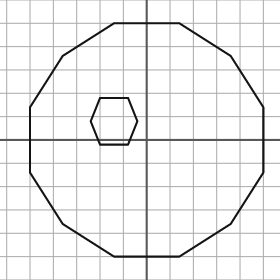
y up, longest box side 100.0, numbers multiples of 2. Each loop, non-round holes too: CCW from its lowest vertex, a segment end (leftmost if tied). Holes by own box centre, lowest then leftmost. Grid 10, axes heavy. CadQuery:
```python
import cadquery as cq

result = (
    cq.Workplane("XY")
    .moveTo(-14.0, -50.0)
    .lineTo(14.0, -50.0)
    .lineTo(36.0, -36.0)
    .lineTo(50.0, -14.0)
    .lineTo(50.0, 14.0)
    .lineTo(36.0, 36.0)
    .lineTo(14.0, 50.0)
    .lineTo(-14.0, 50.0)
    .lineTo(-36.0, 36.0)
    .lineTo(-50.0, 14.0)
    .lineTo(-50.0, -14.0)
    .lineTo(-36.0, -36.0)
    .close()
    .moveTo(-20.0, -2.0)
    .lineTo(-8.0, -2.0)
    .lineTo(-4.0, 8.0)
    .lineTo(-8.0, 18.0)
    .lineTo(-20.0, 18.0)
    .lineTo(-24.0, 8.0)
    .close()
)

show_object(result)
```